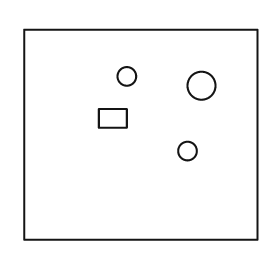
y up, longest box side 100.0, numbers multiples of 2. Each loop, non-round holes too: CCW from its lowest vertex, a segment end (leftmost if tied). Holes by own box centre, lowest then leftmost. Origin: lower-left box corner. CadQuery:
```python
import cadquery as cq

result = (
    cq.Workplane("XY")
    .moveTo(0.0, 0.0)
    .lineTo(100.0, 0.0)
    .lineTo(100.0, 90.0)
    .lineTo(0.0, 90.0)
    .close()
    .moveTo(70.0, 38.0)
    .circle(4.0)
    .moveTo(32.0, 48.0)
    .lineTo(44.0, 48.0)
    .lineTo(44.0, 56.0)
    .lineTo(32.0, 56.0)
    .close()
    .moveTo(76.0, 66.0)
    .circle(6.0)
    .moveTo(44.0, 70.0)
    .circle(4.0)
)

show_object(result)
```